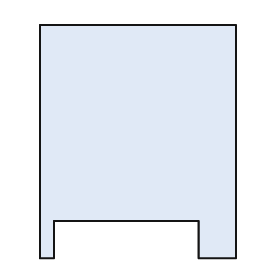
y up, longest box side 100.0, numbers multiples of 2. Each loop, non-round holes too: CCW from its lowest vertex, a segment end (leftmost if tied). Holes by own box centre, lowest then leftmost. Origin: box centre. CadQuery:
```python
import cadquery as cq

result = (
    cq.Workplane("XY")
    .moveTo(-42.0, -50.0)
    .lineTo(-36.0, -50.0)
    .lineTo(-36.0, -34.0)
    .lineTo(26.0, -34.0)
    .lineTo(26.0, -50.0)
    .lineTo(42.0, -50.0)
    .lineTo(42.0, 50.0)
    .lineTo(-42.0, 50.0)
    .close()
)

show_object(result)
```